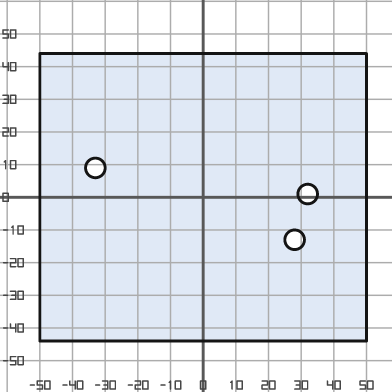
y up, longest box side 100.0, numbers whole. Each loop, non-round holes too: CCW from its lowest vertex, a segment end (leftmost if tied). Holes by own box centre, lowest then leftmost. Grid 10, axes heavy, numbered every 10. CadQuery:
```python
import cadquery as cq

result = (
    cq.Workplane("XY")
    .moveTo(-50.0, -44.0)
    .lineTo(50.0, -44.0)
    .lineTo(50.0, 44.0)
    .lineTo(-50.0, 44.0)
    .close()
    .moveTo(28.0, -13.0)
    .circle(3.0)
    .moveTo(32.0, 1.0)
    .circle(3.0)
    .moveTo(-33.0, 9.0)
    .circle(3.0)
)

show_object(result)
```